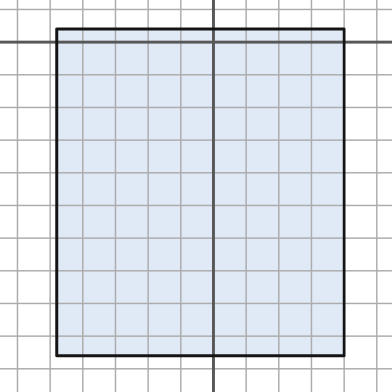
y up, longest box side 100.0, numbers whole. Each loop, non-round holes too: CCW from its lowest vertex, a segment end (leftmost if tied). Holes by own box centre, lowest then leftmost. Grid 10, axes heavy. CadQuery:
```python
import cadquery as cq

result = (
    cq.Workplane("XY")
    .moveTo(-48.0, -96.0)
    .lineTo(40.0, -96.0)
    .lineTo(40.0, 4.0)
    .lineTo(-48.0, 4.0)
    .close()
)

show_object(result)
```